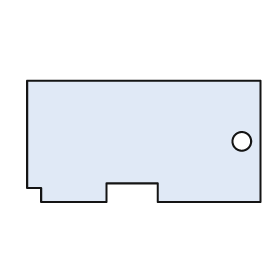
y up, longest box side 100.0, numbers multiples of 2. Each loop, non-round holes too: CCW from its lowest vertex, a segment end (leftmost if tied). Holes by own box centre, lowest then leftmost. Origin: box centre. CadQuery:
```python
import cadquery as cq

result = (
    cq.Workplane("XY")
    .moveTo(-44.0, -26.0)
    .lineTo(-16.0, -26.0)
    .lineTo(-16.0, -18.0)
    .lineTo(6.0, -18.0)
    .lineTo(6.0, -26.0)
    .lineTo(50.0, -26.0)
    .lineTo(50.0, 26.0)
    .lineTo(-50.0, 26.0)
    .lineTo(-50.0, -20.0)
    .lineTo(-44.0, -20.0)
    .close()
    .moveTo(42.0, 0.0)
    .circle(4.0)
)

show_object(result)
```